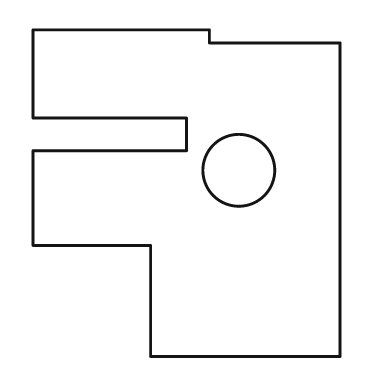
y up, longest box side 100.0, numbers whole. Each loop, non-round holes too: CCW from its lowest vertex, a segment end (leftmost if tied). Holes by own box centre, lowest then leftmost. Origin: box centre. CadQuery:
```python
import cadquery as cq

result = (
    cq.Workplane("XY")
    .moveTo(-11.0, -50.0)
    .lineTo(47.0, -50.0)
    .lineTo(47.0, 46.0)
    .lineTo(7.0, 46.0)
    .lineTo(7.0, 50.0)
    .lineTo(-47.0, 50.0)
    .lineTo(-47.0, 23.0)
    .lineTo(0.0, 23.0)
    .lineTo(0.0, 13.0)
    .lineTo(-47.0, 13.0)
    .lineTo(-47.0, -16.0)
    .lineTo(-11.0, -16.0)
    .close()
    .moveTo(16.0, 7.0)
    .circle(11.0)
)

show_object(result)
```